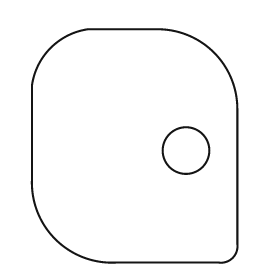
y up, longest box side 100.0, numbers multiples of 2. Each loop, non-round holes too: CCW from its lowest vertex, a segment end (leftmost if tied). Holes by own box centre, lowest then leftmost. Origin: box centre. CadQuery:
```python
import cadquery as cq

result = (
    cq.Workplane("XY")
    .moveTo(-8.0, -50.0)
    .lineTo(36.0, -50.0)
    .threePointArc((42.0, -48.0), (44.0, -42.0))
    .lineTo(44.0, 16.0)
    .threePointArc((34.0, 40.0), (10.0, 50.0))
    .lineTo(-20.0, 50.0)
    .threePointArc((-36.0, 42.0), (-44.0, 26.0))
    .lineTo(-44.0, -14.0)
    .threePointArc((-34.0, -40.0), (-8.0, -50.0))
    .close()
    .moveTo(22.0, -2.0)
    .circle(10.0)
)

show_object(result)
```